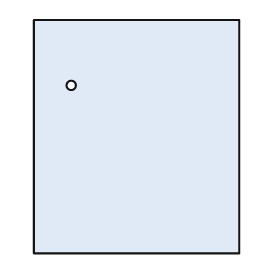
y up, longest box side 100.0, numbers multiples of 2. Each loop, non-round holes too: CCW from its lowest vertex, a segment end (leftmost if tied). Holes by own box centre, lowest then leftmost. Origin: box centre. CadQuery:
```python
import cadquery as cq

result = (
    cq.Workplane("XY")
    .moveTo(-44.0, -50.0)
    .lineTo(44.0, -50.0)
    .lineTo(44.0, 50.0)
    .lineTo(-44.0, 50.0)
    .close()
    .moveTo(-28.0, 22.0)
    .circle(2.0)
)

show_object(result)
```